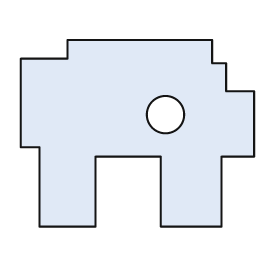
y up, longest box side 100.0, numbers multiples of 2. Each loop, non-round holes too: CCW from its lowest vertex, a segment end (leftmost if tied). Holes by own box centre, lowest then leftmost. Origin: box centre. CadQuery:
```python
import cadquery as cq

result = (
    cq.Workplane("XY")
    .moveTo(-42.0, -40.0)
    .lineTo(-18.0, -40.0)
    .lineTo(-18.0, -10.0)
    .lineTo(10.0, -10.0)
    .lineTo(10.0, -40.0)
    .lineTo(36.0, -40.0)
    .lineTo(36.0, -10.0)
    .lineTo(50.0, -10.0)
    .lineTo(50.0, 18.0)
    .lineTo(38.0, 18.0)
    .lineTo(38.0, 30.0)
    .lineTo(32.0, 30.0)
    .lineTo(32.0, 40.0)
    .lineTo(-30.0, 40.0)
    .lineTo(-30.0, 32.0)
    .lineTo(-50.0, 32.0)
    .lineTo(-50.0, -6.0)
    .lineTo(-42.0, -6.0)
    .close()
    .moveTo(12.0, 8.0)
    .circle(8.0)
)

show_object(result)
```